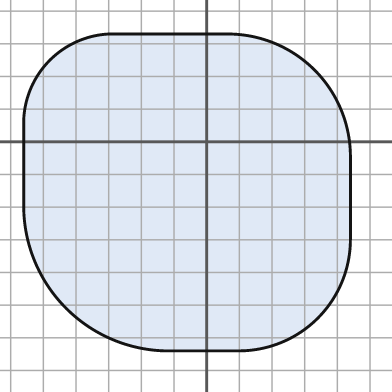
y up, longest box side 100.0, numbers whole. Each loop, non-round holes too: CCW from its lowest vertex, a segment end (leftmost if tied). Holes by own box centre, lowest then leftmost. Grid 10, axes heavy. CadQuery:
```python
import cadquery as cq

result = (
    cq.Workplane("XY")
    .moveTo(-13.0, -64.0)
    .lineTo(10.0, -64.0)
    .threePointArc((34.0, -54.0), (44.0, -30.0))
    .lineTo(44.0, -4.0)
    .threePointArc((33.0, 22.0), (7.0, 33.0))
    .lineTo(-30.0, 33.0)
    .threePointArc((-48.0, 25.0), (-56.0, 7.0))
    .lineTo(-56.0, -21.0)
    .threePointArc((-43.0, -51.0), (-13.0, -64.0))
    .close()
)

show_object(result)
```